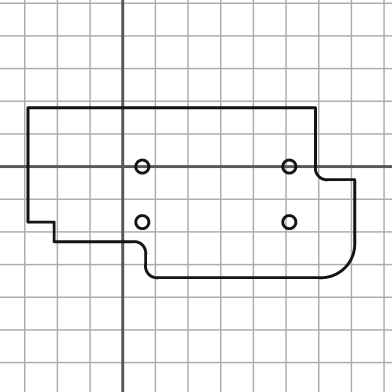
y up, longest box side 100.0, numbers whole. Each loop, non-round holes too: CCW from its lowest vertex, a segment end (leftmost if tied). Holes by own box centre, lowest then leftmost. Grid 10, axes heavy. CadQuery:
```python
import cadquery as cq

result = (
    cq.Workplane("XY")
    .moveTo(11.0, -34.0)
    .lineTo(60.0, -34.0)
    .threePointArc((68.0, -31.0), (71.0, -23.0))
    .lineTo(71.0, -4.0)
    .lineTo(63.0, -4.0)
    .threePointArc((60.0, -3.0), (59.0, 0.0))
    .lineTo(59.0, 18.0)
    .lineTo(-29.0, 18.0)
    .lineTo(-29.0, -17.0)
    .lineTo(-21.0, -17.0)
    .lineTo(-21.0, -23.0)
    .lineTo(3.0, -23.0)
    .threePointArc((6.0, -24.0), (7.0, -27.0))
    .lineTo(7.0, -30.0)
    .threePointArc((8.0, -33.0), (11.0, -34.0))
    .close()
    .moveTo(6.0, -17.0)
    .circle(2.0)
    .moveTo(51.0, -17.0)
    .circle(2.0)
    .moveTo(6.0, 0.0)
    .circle(2.0)
    .moveTo(51.0, 0.0)
    .circle(2.0)
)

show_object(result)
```